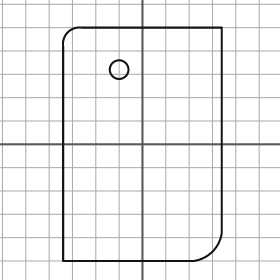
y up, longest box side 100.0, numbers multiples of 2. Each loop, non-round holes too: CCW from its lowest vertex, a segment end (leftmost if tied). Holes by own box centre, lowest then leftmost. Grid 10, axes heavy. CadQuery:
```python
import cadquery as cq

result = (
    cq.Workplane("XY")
    .moveTo(-34.0, -50.0)
    .lineTo(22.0, -50.0)
    .threePointArc((30.0, -46.0), (34.0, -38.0))
    .lineTo(34.0, 50.0)
    .lineTo(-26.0, 50.0)
    .threePointArc((-32.0, 48.0), (-34.0, 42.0))
    .close()
    .moveTo(-10.0, 32.0)
    .circle(4.0)
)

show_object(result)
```